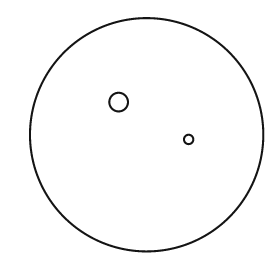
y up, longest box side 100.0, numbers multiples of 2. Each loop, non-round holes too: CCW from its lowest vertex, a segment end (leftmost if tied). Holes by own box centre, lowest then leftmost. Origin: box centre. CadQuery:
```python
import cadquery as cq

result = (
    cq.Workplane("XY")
    .moveTo(0.0, 0.0)
    .circle(50.0)
    .moveTo(18.0, -2.0)
    .circle(2.0)
    .moveTo(-12.0, 14.0)
    .circle(4.0)
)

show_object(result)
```